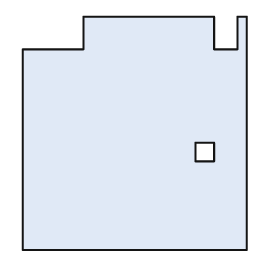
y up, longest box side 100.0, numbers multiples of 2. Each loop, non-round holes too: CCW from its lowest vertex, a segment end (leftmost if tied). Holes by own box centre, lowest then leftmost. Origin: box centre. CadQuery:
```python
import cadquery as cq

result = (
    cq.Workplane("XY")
    .moveTo(-48.0, -50.0)
    .lineTo(48.0, -50.0)
    .lineTo(48.0, 50.0)
    .lineTo(44.0, 50.0)
    .lineTo(44.0, 36.0)
    .lineTo(34.0, 36.0)
    .lineTo(34.0, 50.0)
    .lineTo(-22.0, 50.0)
    .lineTo(-22.0, 36.0)
    .lineTo(-48.0, 36.0)
    .close()
    .moveTo(26.0, -12.0)
    .lineTo(34.0, -12.0)
    .lineTo(34.0, -4.0)
    .lineTo(26.0, -4.0)
    .close()
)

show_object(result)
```